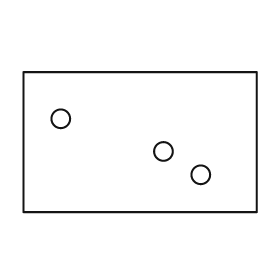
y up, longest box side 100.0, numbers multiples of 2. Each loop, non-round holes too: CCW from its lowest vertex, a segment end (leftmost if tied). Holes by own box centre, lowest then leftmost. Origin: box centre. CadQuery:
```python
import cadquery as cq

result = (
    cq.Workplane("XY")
    .moveTo(-50.0, -30.0)
    .lineTo(50.0, -30.0)
    .lineTo(50.0, 30.0)
    .lineTo(-50.0, 30.0)
    .close()
    .moveTo(26.0, -14.0)
    .circle(4.0)
    .moveTo(10.0, -4.0)
    .circle(4.0)
    .moveTo(-34.0, 10.0)
    .circle(4.0)
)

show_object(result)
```